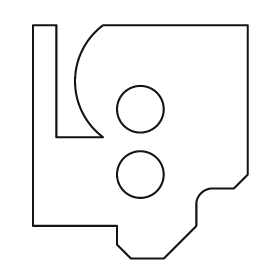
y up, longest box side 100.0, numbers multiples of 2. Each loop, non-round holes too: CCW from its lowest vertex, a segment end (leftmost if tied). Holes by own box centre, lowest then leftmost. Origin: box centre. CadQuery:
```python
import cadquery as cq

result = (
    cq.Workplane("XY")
    .moveTo(-4.0, -50.0)
    .lineTo(10.0, -50.0)
    .lineTo(24.0, -36.0)
    .lineTo(24.0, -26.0)
    .threePointArc((26.0, -22.0), (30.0, -20.0))
    .lineTo(40.0, -20.0)
    .lineTo(46.0, -14.0)
    .lineTo(46.0, 50.0)
    .lineTo(-16.0, 50.0)
    .threePointArc((-28.0, 26.0), (-16.0, 2.0))
    .lineTo(-36.0, 2.0)
    .lineTo(-36.0, 50.0)
    .lineTo(-46.0, 50.0)
    .lineTo(-46.0, -36.0)
    .lineTo(-10.0, -36.0)
    .lineTo(-10.0, -44.0)
    .close()
    .moveTo(0.0, -14.0)
    .circle(10.0)
    .moveTo(0.0, 14.0)
    .circle(10.0)
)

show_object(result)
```